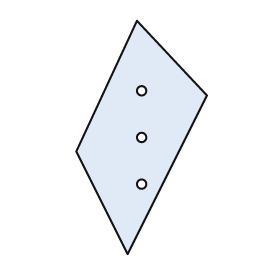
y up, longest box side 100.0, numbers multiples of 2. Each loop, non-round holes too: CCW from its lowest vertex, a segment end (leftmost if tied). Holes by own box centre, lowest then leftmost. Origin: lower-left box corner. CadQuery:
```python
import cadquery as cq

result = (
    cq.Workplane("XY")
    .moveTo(22.0, 0.0)
    .lineTo(56.0, 68.0)
    .lineTo(26.0, 100.0)
    .lineTo(0.0, 44.0)
    .close()
    .moveTo(28.0, 30.0)
    .circle(2.0)
    .moveTo(28.0, 50.0)
    .circle(2.0)
    .moveTo(28.0, 70.0)
    .circle(2.0)
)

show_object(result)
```